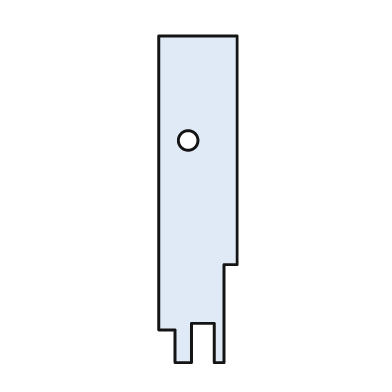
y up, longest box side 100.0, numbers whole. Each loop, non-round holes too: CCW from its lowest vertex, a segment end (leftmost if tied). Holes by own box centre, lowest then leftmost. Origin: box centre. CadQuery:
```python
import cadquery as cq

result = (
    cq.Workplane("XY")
    .moveTo(-7.0, -50.0)
    .lineTo(-2.0, -50.0)
    .lineTo(-2.0, -38.0)
    .lineTo(5.0, -38.0)
    .lineTo(5.0, -50.0)
    .lineTo(8.0, -50.0)
    .lineTo(8.0, -20.0)
    .lineTo(12.0, -20.0)
    .lineTo(12.0, 50.0)
    .lineTo(-12.0, 50.0)
    .lineTo(-12.0, -40.0)
    .lineTo(-7.0, -40.0)
    .close()
    .moveTo(-3.0, 18.0)
    .circle(3.0)
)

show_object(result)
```